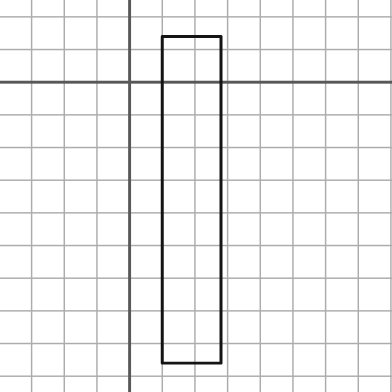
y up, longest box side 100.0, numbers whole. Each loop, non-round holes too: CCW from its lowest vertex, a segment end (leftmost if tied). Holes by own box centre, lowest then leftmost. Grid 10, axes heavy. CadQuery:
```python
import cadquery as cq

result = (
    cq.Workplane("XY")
    .moveTo(10.0, -86.0)
    .lineTo(28.0, -86.0)
    .lineTo(28.0, 14.0)
    .lineTo(10.0, 14.0)
    .close()
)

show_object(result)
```